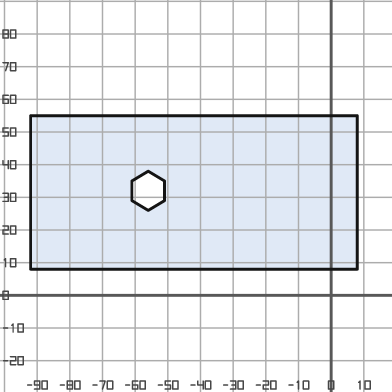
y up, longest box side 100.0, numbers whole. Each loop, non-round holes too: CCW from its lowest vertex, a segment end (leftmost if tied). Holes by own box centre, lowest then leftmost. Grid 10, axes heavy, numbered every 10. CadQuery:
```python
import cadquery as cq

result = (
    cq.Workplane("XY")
    .moveTo(-92.0, 8.0)
    .lineTo(8.0, 8.0)
    .lineTo(8.0, 55.0)
    .lineTo(-92.0, 55.0)
    .close()
    .moveTo(-56.0, 26.0)
    .lineTo(-51.0, 29.0)
    .lineTo(-51.0, 35.0)
    .lineTo(-56.0, 38.0)
    .lineTo(-61.0, 35.0)
    .lineTo(-61.0, 29.0)
    .close()
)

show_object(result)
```